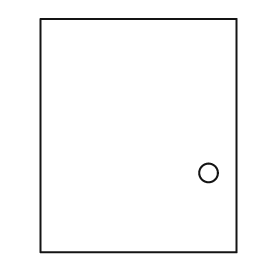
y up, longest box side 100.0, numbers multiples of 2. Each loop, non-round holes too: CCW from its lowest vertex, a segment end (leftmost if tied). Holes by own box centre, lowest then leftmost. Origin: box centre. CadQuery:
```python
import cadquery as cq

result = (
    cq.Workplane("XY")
    .moveTo(-42.0, -50.0)
    .lineTo(42.0, -50.0)
    .lineTo(42.0, 50.0)
    .lineTo(-42.0, 50.0)
    .close()
    .moveTo(30.0, -16.0)
    .circle(4.0)
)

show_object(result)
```